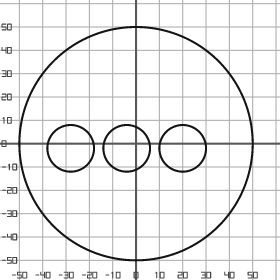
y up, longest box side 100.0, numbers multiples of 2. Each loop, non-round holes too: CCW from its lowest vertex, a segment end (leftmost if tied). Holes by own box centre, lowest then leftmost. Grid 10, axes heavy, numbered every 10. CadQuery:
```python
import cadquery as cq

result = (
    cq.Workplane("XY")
    .moveTo(0.0, 0.0)
    .circle(50.0)
    .moveTo(-28.0, -2.0)
    .circle(10.0)
    .moveTo(-4.0, -2.0)
    .circle(10.0)
    .moveTo(20.0, -2.0)
    .circle(10.0)
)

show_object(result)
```